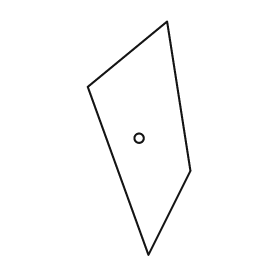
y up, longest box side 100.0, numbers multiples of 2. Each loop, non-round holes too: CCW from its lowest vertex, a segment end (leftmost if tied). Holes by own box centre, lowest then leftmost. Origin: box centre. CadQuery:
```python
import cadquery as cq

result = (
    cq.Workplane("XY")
    .moveTo(4.0, -50.0)
    .lineTo(22.0, -14.0)
    .lineTo(12.0, 50.0)
    .lineTo(-22.0, 22.0)
    .close()
    .moveTo(0.0, 0.0)
    .circle(2.0)
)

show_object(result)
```